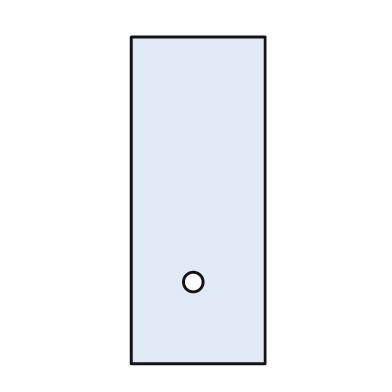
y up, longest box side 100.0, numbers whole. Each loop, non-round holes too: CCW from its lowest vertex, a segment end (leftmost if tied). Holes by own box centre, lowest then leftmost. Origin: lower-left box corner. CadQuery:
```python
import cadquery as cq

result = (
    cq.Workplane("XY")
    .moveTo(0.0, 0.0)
    .lineTo(41.0, 0.0)
    .lineTo(41.0, 100.0)
    .lineTo(0.0, 100.0)
    .close()
    .moveTo(19.0, 25.0)
    .circle(3.0)
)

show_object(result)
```